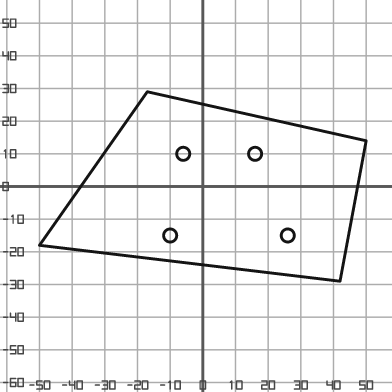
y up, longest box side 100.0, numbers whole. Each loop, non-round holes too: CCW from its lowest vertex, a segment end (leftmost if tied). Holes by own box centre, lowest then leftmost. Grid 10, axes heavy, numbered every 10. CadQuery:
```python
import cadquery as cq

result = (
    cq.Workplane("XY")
    .moveTo(42.0, -29.0)
    .lineTo(50.0, 14.0)
    .lineTo(-17.0, 29.0)
    .lineTo(-50.0, -18.0)
    .close()
    .moveTo(-10.0, -15.0)
    .circle(2.0)
    .moveTo(26.0, -15.0)
    .circle(2.0)
    .moveTo(-6.0, 10.0)
    .circle(2.0)
    .moveTo(16.0, 10.0)
    .circle(2.0)
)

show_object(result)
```